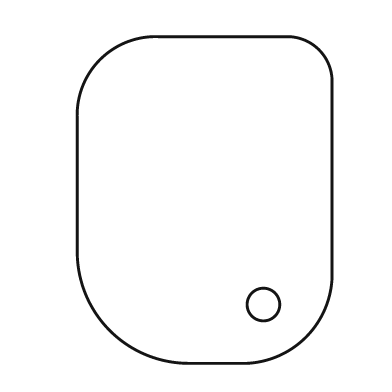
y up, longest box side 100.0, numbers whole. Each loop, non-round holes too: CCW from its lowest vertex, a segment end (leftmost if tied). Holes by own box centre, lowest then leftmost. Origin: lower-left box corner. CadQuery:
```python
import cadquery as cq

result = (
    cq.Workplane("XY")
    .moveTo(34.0, 0.0)
    .lineTo(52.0, 0.0)
    .threePointArc((70.0, 8.0), (78.0, 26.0))
    .lineTo(78.0, 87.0)
    .threePointArc((74.0, 96.0), (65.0, 100.0))
    .lineTo(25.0, 100.0)
    .threePointArc((7.0, 93.0), (0.0, 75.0))
    .lineTo(0.0, 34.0)
    .threePointArc((10.0, 10.0), (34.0, 0.0))
    .close()
    .moveTo(57.0, 18.0)
    .circle(5.0)
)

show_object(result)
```